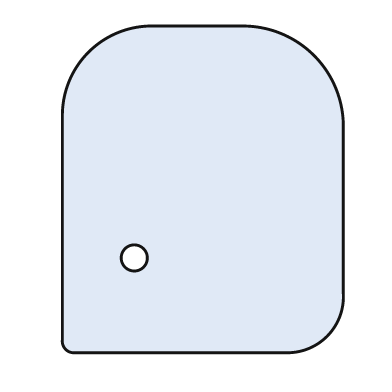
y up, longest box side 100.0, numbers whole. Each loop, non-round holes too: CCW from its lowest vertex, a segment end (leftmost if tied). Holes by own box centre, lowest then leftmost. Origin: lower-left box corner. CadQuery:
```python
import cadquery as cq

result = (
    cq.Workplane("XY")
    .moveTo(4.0, 0.0)
    .lineTo(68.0, 0.0)
    .threePointArc((81.0, 5.0), (86.0, 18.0))
    .lineTo(86.0, 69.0)
    .threePointArc((77.0, 91.0), (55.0, 100.0))
    .lineTo(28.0, 100.0)
    .threePointArc((8.0, 92.0), (0.0, 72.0))
    .lineTo(0.0, 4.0)
    .threePointArc((1.0, 1.0), (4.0, 0.0))
    .close()
    .moveTo(22.0, 29.0)
    .circle(4.0)
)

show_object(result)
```